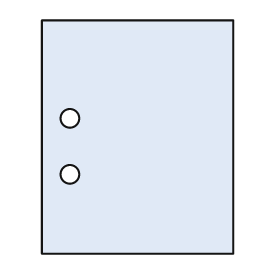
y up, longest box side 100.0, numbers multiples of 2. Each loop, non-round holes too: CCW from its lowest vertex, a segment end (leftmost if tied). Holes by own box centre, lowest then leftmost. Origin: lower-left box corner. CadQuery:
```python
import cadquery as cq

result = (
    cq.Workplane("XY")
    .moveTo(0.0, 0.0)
    .lineTo(82.0, 0.0)
    .lineTo(82.0, 100.0)
    .lineTo(0.0, 100.0)
    .close()
    .moveTo(12.0, 34.0)
    .circle(4.0)
    .moveTo(12.0, 58.0)
    .circle(4.0)
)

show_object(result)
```